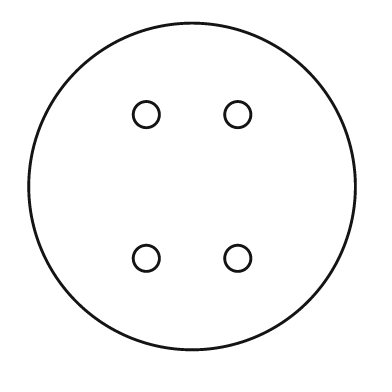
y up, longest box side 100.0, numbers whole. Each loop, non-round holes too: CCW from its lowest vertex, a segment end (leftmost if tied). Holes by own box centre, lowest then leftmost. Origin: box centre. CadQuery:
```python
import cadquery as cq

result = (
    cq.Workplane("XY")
    .moveTo(0.0, 0.0)
    .circle(50.0)
    .moveTo(-14.0, -22.0)
    .circle(4.0)
    .moveTo(14.0, -22.0)
    .circle(4.0)
    .moveTo(-14.0, 22.0)
    .circle(4.0)
    .moveTo(14.0, 22.0)
    .circle(4.0)
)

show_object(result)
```